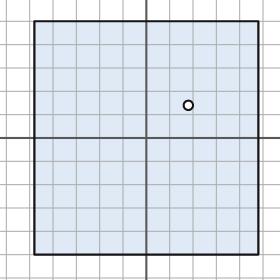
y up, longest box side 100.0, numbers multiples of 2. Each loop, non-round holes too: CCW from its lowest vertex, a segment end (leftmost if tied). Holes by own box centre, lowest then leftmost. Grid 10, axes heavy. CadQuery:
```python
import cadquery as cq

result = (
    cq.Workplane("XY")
    .moveTo(-48.0, -50.0)
    .lineTo(48.0, -50.0)
    .lineTo(48.0, 50.0)
    .lineTo(-48.0, 50.0)
    .close()
    .moveTo(18.0, 14.0)
    .circle(2.0)
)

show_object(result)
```